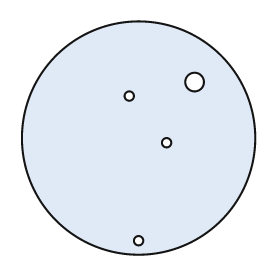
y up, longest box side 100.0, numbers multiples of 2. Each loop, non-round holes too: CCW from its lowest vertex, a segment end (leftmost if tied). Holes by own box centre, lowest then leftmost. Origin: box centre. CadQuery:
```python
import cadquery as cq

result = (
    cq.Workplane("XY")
    .moveTo(0.0, 0.0)
    .circle(50.0)
    .moveTo(0.0, -44.0)
    .circle(2.0)
    .moveTo(12.0, -2.0)
    .circle(2.0)
    .moveTo(-4.0, 18.0)
    .circle(2.0)
    .moveTo(24.0, 24.0)
    .circle(4.0)
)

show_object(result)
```